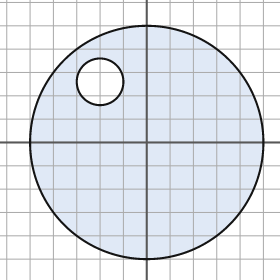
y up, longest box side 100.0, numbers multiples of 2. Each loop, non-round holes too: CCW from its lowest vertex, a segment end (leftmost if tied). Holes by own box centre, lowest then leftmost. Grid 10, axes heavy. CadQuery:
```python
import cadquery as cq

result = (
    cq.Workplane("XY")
    .moveTo(0.0, 0.0)
    .circle(50.0)
    .moveTo(-20.0, 26.0)
    .circle(10.0)
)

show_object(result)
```